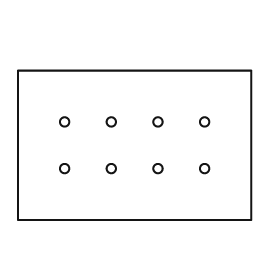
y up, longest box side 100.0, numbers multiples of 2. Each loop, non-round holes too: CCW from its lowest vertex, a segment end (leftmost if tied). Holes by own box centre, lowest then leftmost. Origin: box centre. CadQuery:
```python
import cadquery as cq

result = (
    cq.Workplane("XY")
    .moveTo(-50.0, -32.0)
    .lineTo(50.0, -32.0)
    .lineTo(50.0, 32.0)
    .lineTo(-50.0, 32.0)
    .close()
    .moveTo(-30.0, -10.0)
    .circle(2.0)
    .moveTo(-10.0, -10.0)
    .circle(2.0)
    .moveTo(10.0, -10.0)
    .circle(2.0)
    .moveTo(30.0, -10.0)
    .circle(2.0)
    .moveTo(-30.0, 10.0)
    .circle(2.0)
    .moveTo(-10.0, 10.0)
    .circle(2.0)
    .moveTo(10.0, 10.0)
    .circle(2.0)
    .moveTo(30.0, 10.0)
    .circle(2.0)
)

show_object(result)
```